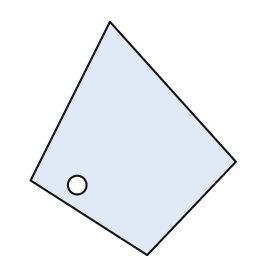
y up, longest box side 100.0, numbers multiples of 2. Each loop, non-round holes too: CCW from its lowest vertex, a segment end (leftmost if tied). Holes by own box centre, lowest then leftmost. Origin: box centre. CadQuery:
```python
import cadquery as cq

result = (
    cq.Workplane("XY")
    .moveTo(6.0, -50.0)
    .lineTo(44.0, -10.0)
    .lineTo(-10.0, 50.0)
    .lineTo(-44.0, -18.0)
    .close()
    .moveTo(-24.0, -20.0)
    .circle(4.0)
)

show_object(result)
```